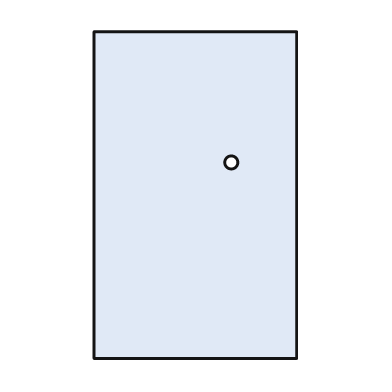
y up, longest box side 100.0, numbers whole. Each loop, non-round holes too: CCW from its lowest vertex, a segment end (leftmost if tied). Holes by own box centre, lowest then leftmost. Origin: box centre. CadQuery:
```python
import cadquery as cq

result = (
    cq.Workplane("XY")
    .moveTo(-31.0, -50.0)
    .lineTo(31.0, -50.0)
    .lineTo(31.0, 50.0)
    .lineTo(-31.0, 50.0)
    .close()
    .moveTo(11.0, 10.0)
    .circle(2.0)
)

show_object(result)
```